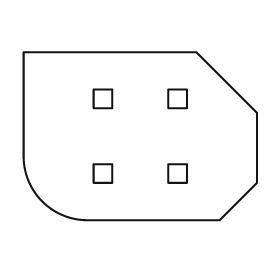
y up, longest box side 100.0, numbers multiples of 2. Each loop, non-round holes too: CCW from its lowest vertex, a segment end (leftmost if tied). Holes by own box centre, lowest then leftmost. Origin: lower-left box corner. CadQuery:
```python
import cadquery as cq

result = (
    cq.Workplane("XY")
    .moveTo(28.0, 0.0)
    .lineTo(84.0, 0.0)
    .lineTo(100.0, 16.0)
    .lineTo(100.0, 46.0)
    .lineTo(74.0, 72.0)
    .lineTo(0.0, 72.0)
    .lineTo(0.0, 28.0)
    .threePointArc((8.0, 8.0), (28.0, 0.0))
    .close()
    .moveTo(30.0, 16.0)
    .lineTo(38.0, 16.0)
    .lineTo(38.0, 24.0)
    .lineTo(30.0, 24.0)
    .close()
    .moveTo(62.0, 16.0)
    .lineTo(70.0, 16.0)
    .lineTo(70.0, 24.0)
    .lineTo(62.0, 24.0)
    .close()
    .moveTo(30.0, 48.0)
    .lineTo(38.0, 48.0)
    .lineTo(38.0, 56.0)
    .lineTo(30.0, 56.0)
    .close()
    .moveTo(62.0, 48.0)
    .lineTo(70.0, 48.0)
    .lineTo(70.0, 56.0)
    .lineTo(62.0, 56.0)
    .close()
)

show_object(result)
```